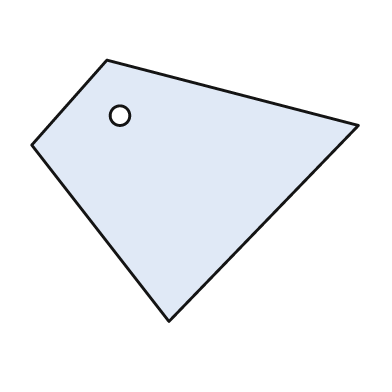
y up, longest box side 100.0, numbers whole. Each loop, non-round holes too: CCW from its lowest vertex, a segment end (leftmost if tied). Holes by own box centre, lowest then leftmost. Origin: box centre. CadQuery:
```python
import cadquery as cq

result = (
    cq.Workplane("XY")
    .moveTo(-8.0, -40.0)
    .lineTo(50.0, 20.0)
    .lineTo(-27.0, 40.0)
    .lineTo(-50.0, 14.0)
    .close()
    .moveTo(-23.0, 23.0)
    .circle(3.0)
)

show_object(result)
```